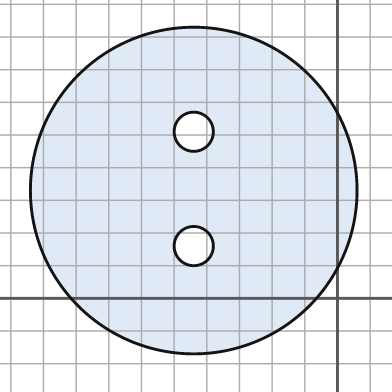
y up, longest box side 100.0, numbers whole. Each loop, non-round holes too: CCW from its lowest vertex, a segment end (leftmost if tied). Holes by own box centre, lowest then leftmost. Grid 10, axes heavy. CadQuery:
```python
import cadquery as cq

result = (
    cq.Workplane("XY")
    .moveTo(-44.0, 33.0)
    .circle(50.0)
    .moveTo(-44.0, 16.0)
    .circle(6.0)
    .moveTo(-44.0, 51.0)
    .circle(6.0)
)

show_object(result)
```